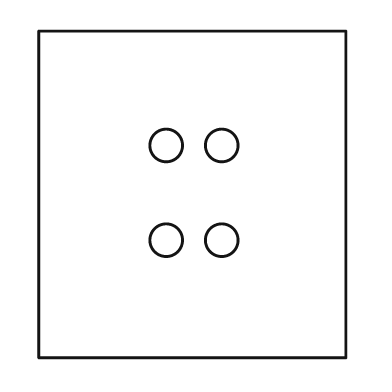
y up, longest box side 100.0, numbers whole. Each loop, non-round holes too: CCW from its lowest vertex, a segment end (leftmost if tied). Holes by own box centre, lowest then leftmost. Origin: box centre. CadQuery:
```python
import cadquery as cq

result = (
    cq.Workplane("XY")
    .moveTo(-47.0, -50.0)
    .lineTo(47.0, -50.0)
    .lineTo(47.0, 50.0)
    .lineTo(-47.0, 50.0)
    .close()
    .moveTo(-8.0, -14.0)
    .circle(5.0)
    .moveTo(9.0, -14.0)
    .circle(5.0)
    .moveTo(-8.0, 15.0)
    .circle(5.0)
    .moveTo(9.0, 15.0)
    .circle(5.0)
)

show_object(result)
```